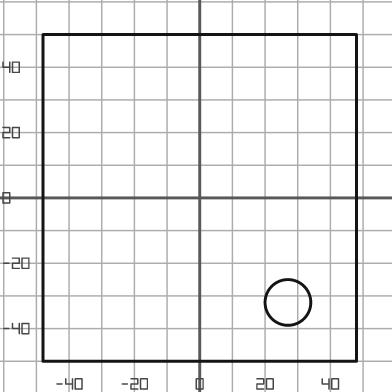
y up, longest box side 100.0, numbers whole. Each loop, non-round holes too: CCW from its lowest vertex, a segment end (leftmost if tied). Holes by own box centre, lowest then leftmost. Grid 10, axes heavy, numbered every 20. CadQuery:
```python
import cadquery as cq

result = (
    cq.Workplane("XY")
    .moveTo(-48.0, -50.0)
    .lineTo(48.0, -50.0)
    .lineTo(48.0, 50.0)
    .lineTo(-48.0, 50.0)
    .close()
    .moveTo(27.0, -32.0)
    .circle(7.0)
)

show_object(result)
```